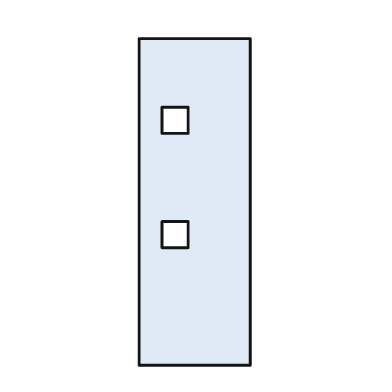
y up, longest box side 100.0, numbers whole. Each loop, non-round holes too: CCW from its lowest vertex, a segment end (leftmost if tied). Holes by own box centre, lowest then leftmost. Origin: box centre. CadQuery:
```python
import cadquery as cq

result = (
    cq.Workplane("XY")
    .moveTo(-17.0, -50.0)
    .lineTo(17.0, -50.0)
    .lineTo(17.0, 50.0)
    .lineTo(-17.0, 50.0)
    .close()
    .moveTo(-10.0, -14.0)
    .lineTo(-2.0, -14.0)
    .lineTo(-2.0, -6.0)
    .lineTo(-10.0, -6.0)
    .close()
    .moveTo(-10.0, 21.0)
    .lineTo(-2.0, 21.0)
    .lineTo(-2.0, 29.0)
    .lineTo(-10.0, 29.0)
    .close()
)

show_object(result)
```